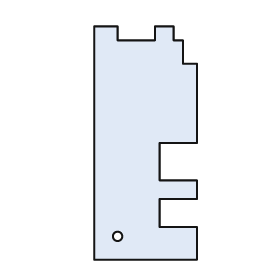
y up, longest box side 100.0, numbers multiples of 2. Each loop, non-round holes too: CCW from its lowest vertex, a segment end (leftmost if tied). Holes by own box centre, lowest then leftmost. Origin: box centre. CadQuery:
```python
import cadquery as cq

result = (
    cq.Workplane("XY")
    .moveTo(-22.0, -50.0)
    .lineTo(22.0, -50.0)
    .lineTo(22.0, -36.0)
    .lineTo(6.0, -36.0)
    .lineTo(6.0, -24.0)
    .lineTo(22.0, -24.0)
    .lineTo(22.0, -16.0)
    .lineTo(6.0, -16.0)
    .lineTo(6.0, 0.0)
    .lineTo(22.0, 0.0)
    .lineTo(22.0, 34.0)
    .lineTo(16.0, 34.0)
    .lineTo(16.0, 44.0)
    .lineTo(12.0, 44.0)
    .lineTo(12.0, 50.0)
    .lineTo(4.0, 50.0)
    .lineTo(4.0, 44.0)
    .lineTo(-12.0, 44.0)
    .lineTo(-12.0, 50.0)
    .lineTo(-22.0, 50.0)
    .close()
    .moveTo(-12.0, -40.0)
    .circle(2.0)
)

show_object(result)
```